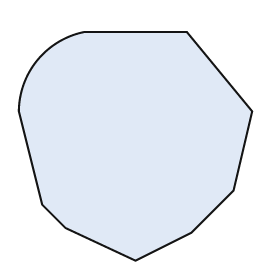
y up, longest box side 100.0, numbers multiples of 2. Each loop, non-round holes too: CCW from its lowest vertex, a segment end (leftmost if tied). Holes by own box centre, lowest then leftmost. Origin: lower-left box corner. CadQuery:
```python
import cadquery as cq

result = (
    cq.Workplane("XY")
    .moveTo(50.0, 0.0)
    .lineTo(74.0, 12.0)
    .lineTo(92.0, 30.0)
    .lineTo(100.0, 64.0)
    .lineTo(72.0, 98.0)
    .lineTo(28.0, 98.0)
    .threePointArc((8.0, 86.0), (0.0, 64.0))
    .lineTo(10.0, 24.0)
    .lineTo(20.0, 14.0)
    .close()
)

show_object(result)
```